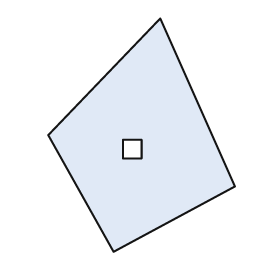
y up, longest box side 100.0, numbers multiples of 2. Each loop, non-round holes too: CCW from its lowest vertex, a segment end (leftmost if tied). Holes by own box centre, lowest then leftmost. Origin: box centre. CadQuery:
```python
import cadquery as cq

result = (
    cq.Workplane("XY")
    .moveTo(-12.0, -50.0)
    .lineTo(40.0, -22.0)
    .lineTo(8.0, 50.0)
    .lineTo(-40.0, 0.0)
    .close()
    .moveTo(-8.0, -10.0)
    .lineTo(0.0, -10.0)
    .lineTo(0.0, -2.0)
    .lineTo(-8.0, -2.0)
    .close()
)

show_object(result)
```